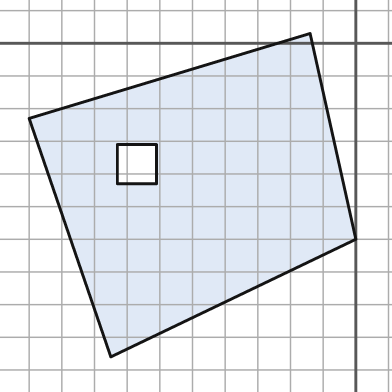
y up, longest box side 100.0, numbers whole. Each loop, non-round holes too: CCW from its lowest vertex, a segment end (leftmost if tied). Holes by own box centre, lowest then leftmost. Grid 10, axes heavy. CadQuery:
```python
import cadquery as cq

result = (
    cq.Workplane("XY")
    .moveTo(-75.0, -96.0)
    .lineTo(0.0, -60.0)
    .lineTo(-14.0, 3.0)
    .lineTo(-100.0, -23.0)
    .close()
    .moveTo(-73.0, -43.0)
    .lineTo(-61.0, -43.0)
    .lineTo(-61.0, -31.0)
    .lineTo(-73.0, -31.0)
    .close()
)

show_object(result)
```